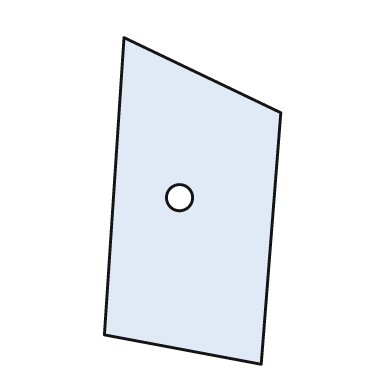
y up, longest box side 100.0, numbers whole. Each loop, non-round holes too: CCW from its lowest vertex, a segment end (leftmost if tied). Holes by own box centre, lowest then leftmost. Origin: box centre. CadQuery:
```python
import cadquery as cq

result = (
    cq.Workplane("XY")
    .moveTo(21.0, -50.0)
    .lineTo(27.0, 27.0)
    .lineTo(-21.0, 50.0)
    .lineTo(-27.0, -41.0)
    .close()
    .moveTo(-4.0, 1.0)
    .circle(4.0)
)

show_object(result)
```